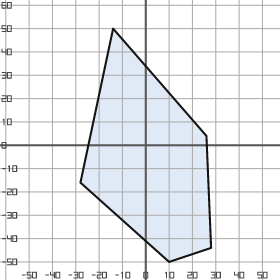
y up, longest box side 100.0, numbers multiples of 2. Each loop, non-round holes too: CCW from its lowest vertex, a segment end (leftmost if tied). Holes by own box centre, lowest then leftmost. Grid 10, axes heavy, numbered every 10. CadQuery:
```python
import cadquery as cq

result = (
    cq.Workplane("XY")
    .moveTo(10.0, -50.0)
    .lineTo(28.0, -44.0)
    .lineTo(26.0, 4.0)
    .lineTo(-14.0, 50.0)
    .lineTo(-28.0, -16.0)
    .close()
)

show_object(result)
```